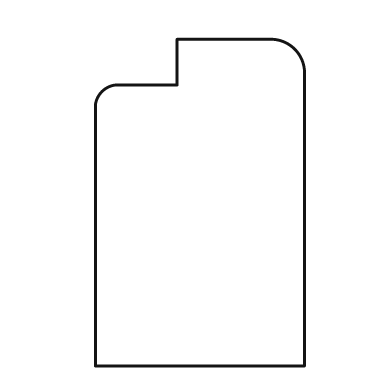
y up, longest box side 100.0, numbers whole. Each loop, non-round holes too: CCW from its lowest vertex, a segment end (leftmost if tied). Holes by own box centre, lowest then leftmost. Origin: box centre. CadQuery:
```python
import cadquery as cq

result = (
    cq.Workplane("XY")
    .moveTo(-32.0, -50.0)
    .lineTo(32.0, -50.0)
    .lineTo(32.0, 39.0)
    .threePointArc((29.0, 47.0), (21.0, 50.0))
    .lineTo(-7.0, 50.0)
    .lineTo(-7.0, 36.0)
    .lineTo(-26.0, 36.0)
    .threePointArc((-30.0, 34.0), (-32.0, 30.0))
    .close()
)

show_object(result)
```